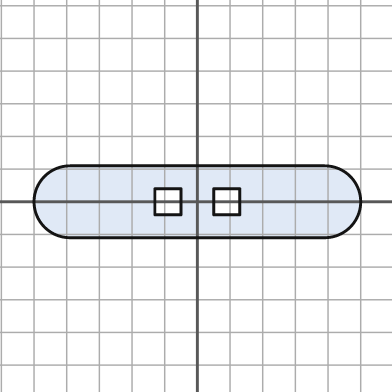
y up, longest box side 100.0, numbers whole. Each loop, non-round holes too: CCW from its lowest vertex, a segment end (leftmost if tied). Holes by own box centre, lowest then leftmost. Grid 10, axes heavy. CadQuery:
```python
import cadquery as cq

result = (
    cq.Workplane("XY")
    .moveTo(-39.0, -11.0)
    .lineTo(39.0, -11.0)
    .threePointArc((50.0, 0.0), (39.0, 11.0))
    .lineTo(-39.0, 11.0)
    .threePointArc((-50.0, 0.0), (-39.0, -11.0))
    .close()
    .moveTo(-13.0, -4.0)
    .lineTo(-5.0, -4.0)
    .lineTo(-5.0, 4.0)
    .lineTo(-13.0, 4.0)
    .close()
    .moveTo(5.0, -4.0)
    .lineTo(13.0, -4.0)
    .lineTo(13.0, 4.0)
    .lineTo(5.0, 4.0)
    .close()
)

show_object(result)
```